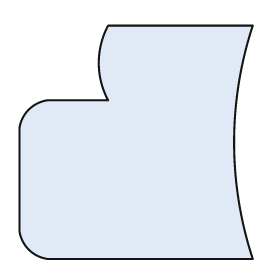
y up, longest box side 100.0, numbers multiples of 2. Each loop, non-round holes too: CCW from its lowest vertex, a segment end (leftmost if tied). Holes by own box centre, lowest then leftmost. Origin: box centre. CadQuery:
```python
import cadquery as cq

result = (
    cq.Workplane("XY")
    .moveTo(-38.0, -50.0)
    .lineTo(50.0, -50.0)
    .threePointArc((42.0, 0.0), (50.0, 50.0))
    .lineTo(-12.0, 50.0)
    .threePointArc((-16.0, 34.0), (-12.0, 18.0))
    .lineTo(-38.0, 18.0)
    .threePointArc((-46.0, 14.0), (-50.0, 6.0))
    .lineTo(-50.0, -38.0)
    .threePointArc((-46.0, -46.0), (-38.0, -50.0))
    .close()
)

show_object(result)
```